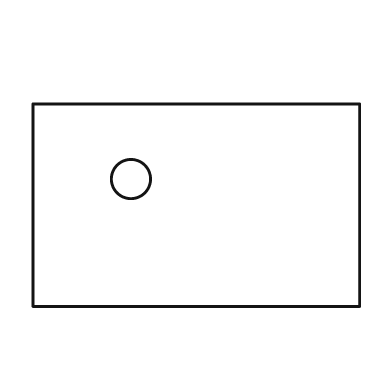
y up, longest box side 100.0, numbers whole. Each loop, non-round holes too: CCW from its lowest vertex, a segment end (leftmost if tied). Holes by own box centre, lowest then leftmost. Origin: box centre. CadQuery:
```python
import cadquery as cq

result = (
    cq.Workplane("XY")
    .moveTo(-50.0, -31.0)
    .lineTo(50.0, -31.0)
    .lineTo(50.0, 31.0)
    .lineTo(-50.0, 31.0)
    .close()
    .moveTo(-20.0, 8.0)
    .circle(6.0)
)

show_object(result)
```